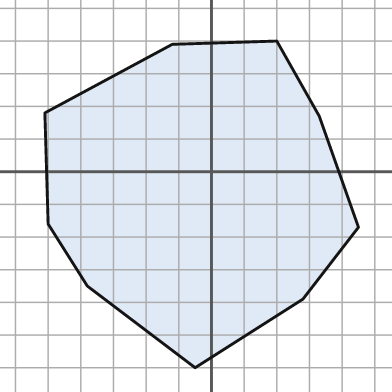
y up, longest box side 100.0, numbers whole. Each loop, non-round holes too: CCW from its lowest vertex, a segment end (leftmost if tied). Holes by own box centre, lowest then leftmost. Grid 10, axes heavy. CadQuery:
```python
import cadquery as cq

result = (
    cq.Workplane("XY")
    .moveTo(-5.0, -60.0)
    .lineTo(28.0, -39.0)
    .lineTo(45.0, -17.0)
    .lineTo(33.0, 17.0)
    .lineTo(20.0, 40.0)
    .lineTo(-12.0, 39.0)
    .lineTo(-51.0, 18.0)
    .lineTo(-50.0, -16.0)
    .lineTo(-38.0, -35.0)
    .close()
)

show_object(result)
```